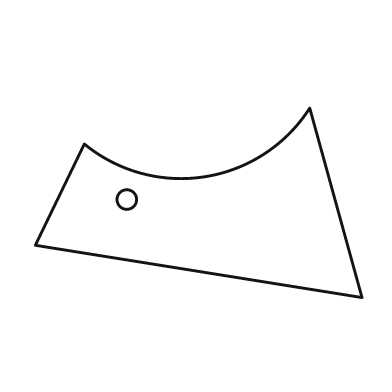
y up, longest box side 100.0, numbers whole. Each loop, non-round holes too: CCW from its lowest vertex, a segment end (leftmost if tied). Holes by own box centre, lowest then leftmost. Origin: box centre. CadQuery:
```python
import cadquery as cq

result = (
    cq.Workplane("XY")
    .moveTo(50.0, -29.0)
    .lineTo(34.0, 29.0)
    .threePointArc((2.0, 8.0), (-35.0, 18.0))
    .lineTo(-50.0, -13.0)
    .close()
    .moveTo(-22.0, 1.0)
    .circle(3.0)
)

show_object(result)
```